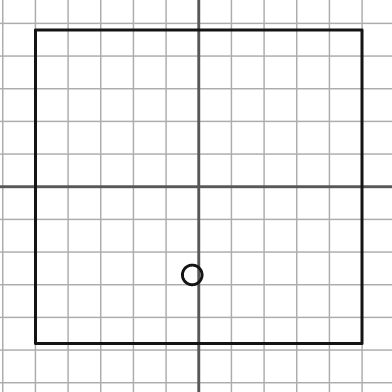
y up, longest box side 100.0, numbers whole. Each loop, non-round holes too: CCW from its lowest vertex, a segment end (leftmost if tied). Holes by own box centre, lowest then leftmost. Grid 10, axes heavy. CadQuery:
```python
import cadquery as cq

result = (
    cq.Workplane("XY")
    .moveTo(-50.0, -48.0)
    .lineTo(50.0, -48.0)
    .lineTo(50.0, 48.0)
    .lineTo(-50.0, 48.0)
    .close()
    .moveTo(-2.0, -27.0)
    .circle(3.0)
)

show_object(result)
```